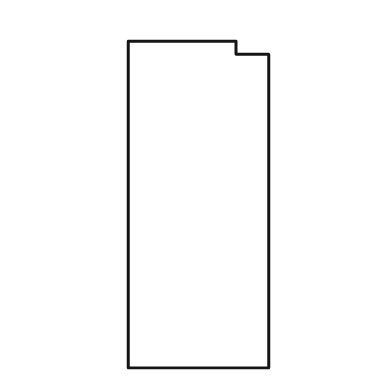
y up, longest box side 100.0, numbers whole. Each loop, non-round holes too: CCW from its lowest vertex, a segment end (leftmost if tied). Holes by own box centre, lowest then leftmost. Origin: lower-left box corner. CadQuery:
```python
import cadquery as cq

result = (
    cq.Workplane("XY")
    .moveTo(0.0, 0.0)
    .lineTo(43.0, 0.0)
    .lineTo(43.0, 96.0)
    .lineTo(33.0, 96.0)
    .lineTo(33.0, 100.0)
    .lineTo(0.0, 100.0)
    .close()
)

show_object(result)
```